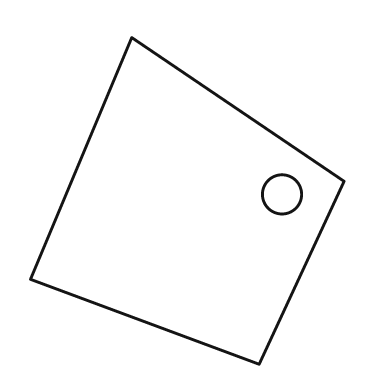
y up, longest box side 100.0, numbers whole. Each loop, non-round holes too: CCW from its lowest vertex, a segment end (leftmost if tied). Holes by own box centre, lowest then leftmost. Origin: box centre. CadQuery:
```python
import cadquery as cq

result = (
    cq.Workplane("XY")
    .moveTo(22.0, -50.0)
    .lineTo(48.0, 6.0)
    .lineTo(-17.0, 50.0)
    .lineTo(-48.0, -24.0)
    .close()
    .moveTo(29.0, 2.0)
    .circle(6.0)
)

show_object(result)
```